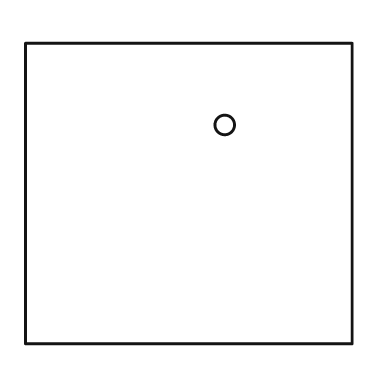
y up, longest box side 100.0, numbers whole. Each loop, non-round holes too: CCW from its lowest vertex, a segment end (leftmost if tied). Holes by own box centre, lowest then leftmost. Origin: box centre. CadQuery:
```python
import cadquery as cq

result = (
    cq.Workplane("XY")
    .moveTo(-50.0, -46.0)
    .lineTo(50.0, -46.0)
    .lineTo(50.0, 46.0)
    .lineTo(-50.0, 46.0)
    .close()
    .moveTo(11.0, 21.0)
    .circle(3.0)
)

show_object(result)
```